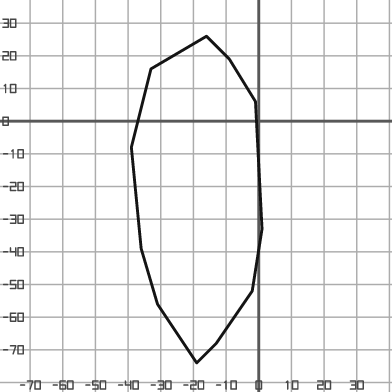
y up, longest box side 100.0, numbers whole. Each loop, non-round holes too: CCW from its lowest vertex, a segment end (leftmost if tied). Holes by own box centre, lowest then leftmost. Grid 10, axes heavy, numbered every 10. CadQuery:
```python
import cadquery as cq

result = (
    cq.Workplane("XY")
    .moveTo(-19.0, -74.0)
    .lineTo(-13.0, -68.0)
    .lineTo(-2.0, -52.0)
    .lineTo(1.0, -33.0)
    .lineTo(-1.0, 6.0)
    .lineTo(-9.0, 19.0)
    .lineTo(-16.0, 26.0)
    .lineTo(-33.0, 16.0)
    .lineTo(-39.0, -8.0)
    .lineTo(-36.0, -39.0)
    .lineTo(-31.0, -56.0)
    .close()
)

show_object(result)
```